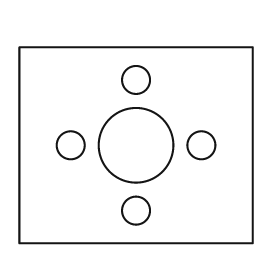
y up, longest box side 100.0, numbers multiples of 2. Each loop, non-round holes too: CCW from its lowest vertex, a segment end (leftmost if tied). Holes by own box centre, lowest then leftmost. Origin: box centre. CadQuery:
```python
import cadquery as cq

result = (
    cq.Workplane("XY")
    .moveTo(-50.0, -42.0)
    .lineTo(50.0, -42.0)
    .lineTo(50.0, 42.0)
    .lineTo(-50.0, 42.0)
    .close()
    .moveTo(0.0, -28.0)
    .circle(6.0)
    .moveTo(-28.0, 0.0)
    .circle(6.0)
    .moveTo(0.0, 0.0)
    .circle(16.0)
    .moveTo(28.0, 0.0)
    .circle(6.0)
    .moveTo(0.0, 28.0)
    .circle(6.0)
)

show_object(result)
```